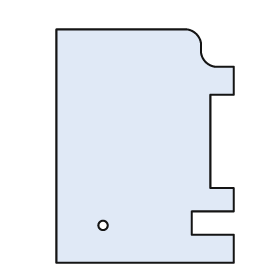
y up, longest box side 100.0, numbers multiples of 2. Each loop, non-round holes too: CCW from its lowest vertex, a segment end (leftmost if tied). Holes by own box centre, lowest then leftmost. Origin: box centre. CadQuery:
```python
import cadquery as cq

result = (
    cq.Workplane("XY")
    .moveTo(-38.0, -50.0)
    .lineTo(38.0, -50.0)
    .lineTo(38.0, -38.0)
    .lineTo(20.0, -38.0)
    .lineTo(20.0, -28.0)
    .lineTo(38.0, -28.0)
    .lineTo(38.0, -18.0)
    .lineTo(28.0, -18.0)
    .lineTo(28.0, 22.0)
    .lineTo(38.0, 22.0)
    .lineTo(38.0, 34.0)
    .lineTo(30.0, 34.0)
    .threePointArc((26.0, 36.0), (24.0, 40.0))
    .lineTo(24.0, 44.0)
    .threePointArc((22.0, 48.0), (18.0, 50.0))
    .lineTo(-38.0, 50.0)
    .close()
    .moveTo(-18.0, -34.0)
    .circle(2.0)
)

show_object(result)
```